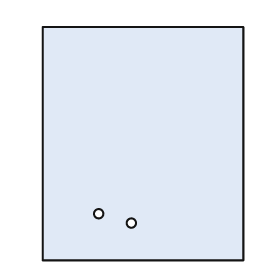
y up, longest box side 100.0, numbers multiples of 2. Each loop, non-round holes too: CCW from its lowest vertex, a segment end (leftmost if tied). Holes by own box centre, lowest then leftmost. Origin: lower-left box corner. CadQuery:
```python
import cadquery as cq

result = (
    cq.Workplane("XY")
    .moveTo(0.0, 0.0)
    .lineTo(86.0, 0.0)
    .lineTo(86.0, 100.0)
    .lineTo(0.0, 100.0)
    .close()
    .moveTo(38.0, 16.0)
    .circle(2.0)
    .moveTo(24.0, 20.0)
    .circle(2.0)
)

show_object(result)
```